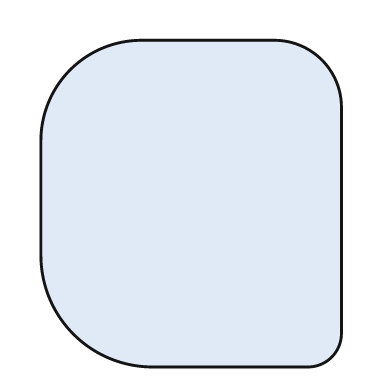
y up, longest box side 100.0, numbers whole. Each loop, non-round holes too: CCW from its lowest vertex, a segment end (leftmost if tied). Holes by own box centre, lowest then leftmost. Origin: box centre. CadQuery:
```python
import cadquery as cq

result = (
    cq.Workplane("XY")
    .moveTo(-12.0, -50.0)
    .lineTo(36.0, -50.0)
    .threePointArc((43.0, -47.0), (46.0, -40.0))
    .lineTo(46.0, 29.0)
    .threePointArc((40.0, 44.0), (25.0, 50.0))
    .lineTo(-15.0, 50.0)
    .threePointArc((-37.0, 41.0), (-46.0, 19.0))
    .lineTo(-46.0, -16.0)
    .threePointArc((-36.0, -40.0), (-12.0, -50.0))
    .close()
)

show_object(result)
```